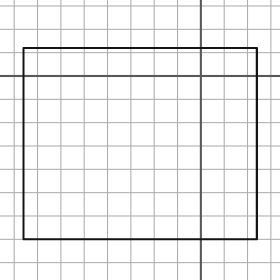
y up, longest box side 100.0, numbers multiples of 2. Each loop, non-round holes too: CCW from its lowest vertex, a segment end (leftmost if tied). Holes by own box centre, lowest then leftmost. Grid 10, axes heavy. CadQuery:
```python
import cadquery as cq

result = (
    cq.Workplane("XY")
    .moveTo(-76.0, -70.0)
    .lineTo(24.0, -70.0)
    .lineTo(24.0, 12.0)
    .lineTo(-76.0, 12.0)
    .close()
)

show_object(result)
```